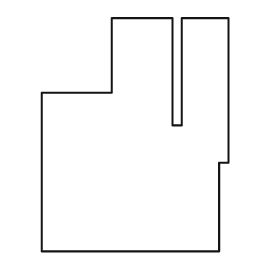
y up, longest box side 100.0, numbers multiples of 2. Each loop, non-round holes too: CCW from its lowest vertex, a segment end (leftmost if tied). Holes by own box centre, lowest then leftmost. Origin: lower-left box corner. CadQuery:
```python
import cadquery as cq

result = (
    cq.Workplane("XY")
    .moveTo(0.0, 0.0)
    .lineTo(76.0, 0.0)
    .lineTo(76.0, 38.0)
    .lineTo(80.0, 38.0)
    .lineTo(80.0, 100.0)
    .lineTo(60.0, 100.0)
    .lineTo(60.0, 54.0)
    .lineTo(56.0, 54.0)
    .lineTo(56.0, 100.0)
    .lineTo(30.0, 100.0)
    .lineTo(30.0, 68.0)
    .lineTo(0.0, 68.0)
    .close()
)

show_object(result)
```